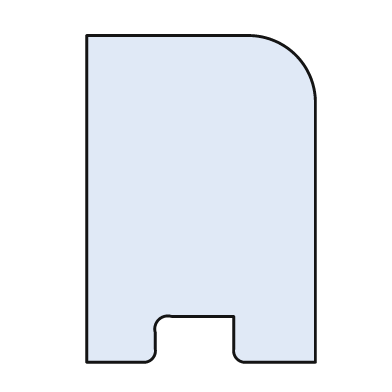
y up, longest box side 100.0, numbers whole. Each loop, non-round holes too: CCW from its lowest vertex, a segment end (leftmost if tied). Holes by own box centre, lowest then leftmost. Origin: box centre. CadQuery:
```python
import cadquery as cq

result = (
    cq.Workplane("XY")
    .moveTo(-35.0, -50.0)
    .lineTo(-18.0, -50.0)
    .threePointArc((-15.0, -49.0), (-14.0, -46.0))
    .lineTo(-14.0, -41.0)
    .threePointArc((-13.0, -37.0), (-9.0, -36.0))
    .lineTo(10.0, -36.0)
    .lineTo(10.0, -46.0)
    .threePointArc((11.0, -49.0), (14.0, -50.0))
    .lineTo(35.0, -50.0)
    .lineTo(35.0, 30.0)
    .threePointArc((29.0, 44.0), (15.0, 50.0))
    .lineTo(-35.0, 50.0)
    .close()
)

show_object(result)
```